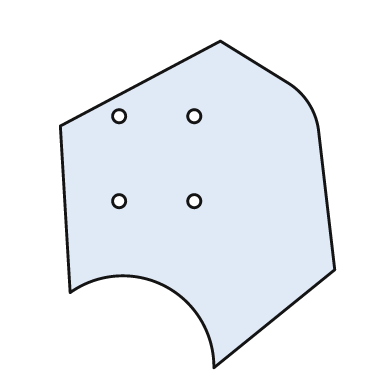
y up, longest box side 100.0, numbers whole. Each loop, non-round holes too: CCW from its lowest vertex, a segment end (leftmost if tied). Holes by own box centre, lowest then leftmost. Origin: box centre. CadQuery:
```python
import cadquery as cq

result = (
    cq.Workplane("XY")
    .moveTo(5.0, -50.0)
    .lineTo(42.0, -20.0)
    .lineTo(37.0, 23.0)
    .threePointArc((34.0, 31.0), (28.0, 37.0))
    .lineTo(7.0, 50.0)
    .lineTo(-42.0, 24.0)
    .lineTo(-39.0, -27.0)
    .threePointArc((-10.0, -25.0), (5.0, -50.0))
    .close()
    .moveTo(-24.0, 1.0)
    .circle(2.0)
    .moveTo(-1.0, 1.0)
    .circle(2.0)
    .moveTo(-24.0, 27.0)
    .circle(2.0)
    .moveTo(-1.0, 27.0)
    .circle(2.0)
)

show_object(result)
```